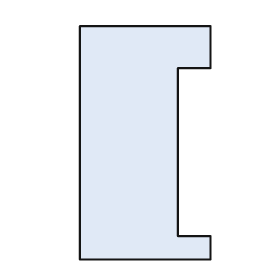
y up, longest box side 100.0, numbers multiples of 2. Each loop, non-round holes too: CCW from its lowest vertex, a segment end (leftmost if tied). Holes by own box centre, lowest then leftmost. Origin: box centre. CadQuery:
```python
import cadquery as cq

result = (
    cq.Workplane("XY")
    .moveTo(-28.0, -50.0)
    .lineTo(28.0, -50.0)
    .lineTo(28.0, -40.0)
    .lineTo(14.0, -40.0)
    .lineTo(14.0, 32.0)
    .lineTo(28.0, 32.0)
    .lineTo(28.0, 50.0)
    .lineTo(-28.0, 50.0)
    .close()
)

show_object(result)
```